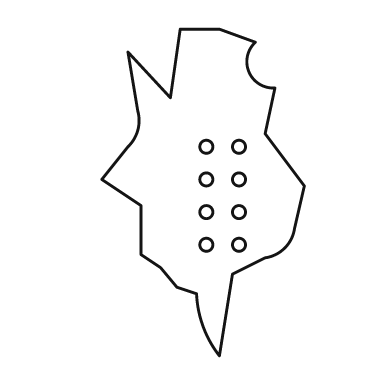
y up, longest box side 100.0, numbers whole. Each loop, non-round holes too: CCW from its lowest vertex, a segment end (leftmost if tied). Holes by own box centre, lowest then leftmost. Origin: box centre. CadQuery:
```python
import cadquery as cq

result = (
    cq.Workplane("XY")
    .moveTo(5.0, -50.0)
    .lineTo(9.0, -25.0)
    .lineTo(19.0, -20.0)
    .threePointArc((25.0, -17.0), (28.0, -11.0))
    .lineTo(31.0, 2.0)
    .lineTo(19.0, 18.0)
    .lineTo(22.0, 32.0)
    .threePointArc((14.0, 37.0), (16.0, 46.0))
    .lineTo(5.0, 50.0)
    .lineTo(-7.0, 50.0)
    .lineTo(-10.0, 29.0)
    .lineTo(-23.0, 43.0)
    .lineTo(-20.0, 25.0)
    .threePointArc((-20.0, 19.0), (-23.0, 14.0))
    .lineTo(-31.0, 4.0)
    .lineTo(-19.0, -4.0)
    .lineTo(-19.0, -19.0)
    .lineTo(-13.0, -23.0)
    .lineTo(-8.0, -29.0)
    .lineTo(-2.0, -31.0)
    .threePointArc((0.0, -41.0), (5.0, -50.0))
    .close()
    .moveTo(1.0, -16.0)
    .circle(2.0)
    .moveTo(11.0, -16.0)
    .circle(2.0)
    .moveTo(1.0, -6.0)
    .circle(2.0)
    .moveTo(11.0, -6.0)
    .circle(2.0)
    .moveTo(1.0, 4.0)
    .circle(2.0)
    .moveTo(11.0, 4.0)
    .circle(2.0)
    .moveTo(1.0, 14.0)
    .circle(2.0)
    .moveTo(11.0, 14.0)
    .circle(2.0)
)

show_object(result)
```